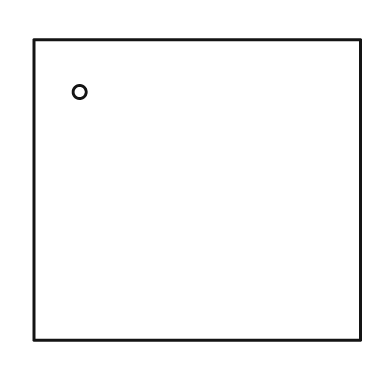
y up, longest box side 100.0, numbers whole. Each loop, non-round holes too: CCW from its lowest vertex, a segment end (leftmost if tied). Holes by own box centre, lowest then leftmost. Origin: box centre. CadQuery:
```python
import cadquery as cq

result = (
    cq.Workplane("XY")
    .moveTo(-50.0, -46.0)
    .lineTo(50.0, -46.0)
    .lineTo(50.0, 46.0)
    .lineTo(-50.0, 46.0)
    .close()
    .moveTo(-36.0, 30.0)
    .circle(2.0)
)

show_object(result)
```